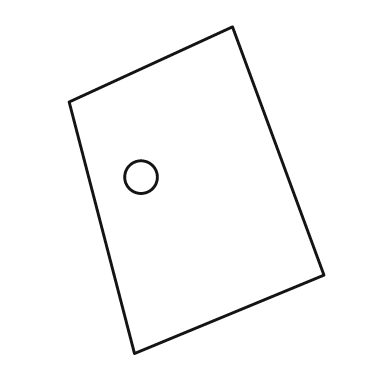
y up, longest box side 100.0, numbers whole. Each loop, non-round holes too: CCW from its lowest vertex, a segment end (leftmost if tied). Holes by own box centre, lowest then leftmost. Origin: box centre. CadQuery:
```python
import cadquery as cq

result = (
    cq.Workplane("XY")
    .moveTo(-19.0, -50.0)
    .lineTo(39.0, -26.0)
    .lineTo(11.0, 50.0)
    .lineTo(-39.0, 27.0)
    .close()
    .moveTo(-17.0, 4.0)
    .circle(5.0)
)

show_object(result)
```